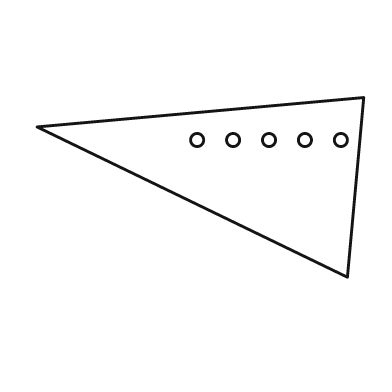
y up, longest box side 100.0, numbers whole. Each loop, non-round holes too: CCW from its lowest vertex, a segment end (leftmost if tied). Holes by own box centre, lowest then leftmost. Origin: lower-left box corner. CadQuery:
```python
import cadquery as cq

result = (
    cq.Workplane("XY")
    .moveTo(95.0, 0.0)
    .lineTo(100.0, 55.0)
    .lineTo(0.0, 46.0)
    .close()
    .moveTo(49.0, 42.0)
    .circle(2.0)
    .moveTo(60.0, 42.0)
    .circle(2.0)
    .moveTo(71.0, 42.0)
    .circle(2.0)
    .moveTo(82.0, 42.0)
    .circle(2.0)
    .moveTo(93.0, 42.0)
    .circle(2.0)
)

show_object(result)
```